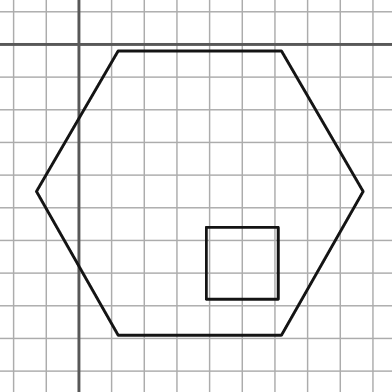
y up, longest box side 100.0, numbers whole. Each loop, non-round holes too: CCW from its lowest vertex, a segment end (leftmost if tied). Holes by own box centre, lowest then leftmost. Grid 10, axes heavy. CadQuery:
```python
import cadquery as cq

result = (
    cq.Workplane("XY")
    .moveTo(12.0, -89.0)
    .lineTo(62.0, -89.0)
    .lineTo(87.0, -45.0)
    .lineTo(62.0, -2.0)
    .lineTo(12.0, -2.0)
    .lineTo(-13.0, -45.0)
    .close()
    .moveTo(39.0, -78.0)
    .lineTo(61.0, -78.0)
    .lineTo(61.0, -56.0)
    .lineTo(39.0, -56.0)
    .close()
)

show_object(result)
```